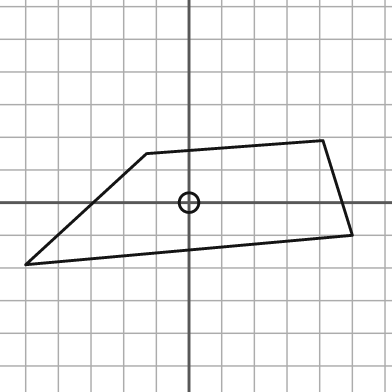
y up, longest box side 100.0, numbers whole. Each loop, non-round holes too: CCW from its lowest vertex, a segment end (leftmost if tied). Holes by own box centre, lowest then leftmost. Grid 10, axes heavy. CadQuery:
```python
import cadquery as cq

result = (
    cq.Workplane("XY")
    .moveTo(-50.0, -19.0)
    .lineTo(50.0, -10.0)
    .lineTo(41.0, 19.0)
    .lineTo(-13.0, 15.0)
    .close()
    .moveTo(0.0, 0.0)
    .circle(3.0)
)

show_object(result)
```